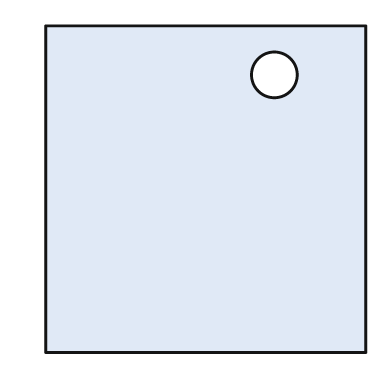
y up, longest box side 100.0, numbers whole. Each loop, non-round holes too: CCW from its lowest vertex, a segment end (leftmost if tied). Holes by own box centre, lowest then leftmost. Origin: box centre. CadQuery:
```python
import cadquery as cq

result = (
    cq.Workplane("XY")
    .moveTo(-49.0, -50.0)
    .lineTo(49.0, -50.0)
    .lineTo(49.0, 50.0)
    .lineTo(-49.0, 50.0)
    .close()
    .moveTo(21.0, 35.0)
    .circle(7.0)
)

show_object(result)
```